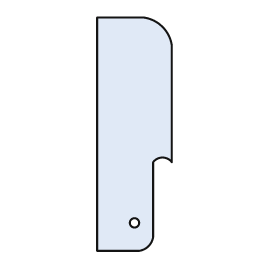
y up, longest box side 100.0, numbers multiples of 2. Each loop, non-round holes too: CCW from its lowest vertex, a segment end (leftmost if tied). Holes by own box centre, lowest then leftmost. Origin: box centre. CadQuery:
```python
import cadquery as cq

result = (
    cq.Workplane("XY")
    .moveTo(-16.0, -50.0)
    .lineTo(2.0, -50.0)
    .threePointArc((6.0, -48.0), (8.0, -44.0))
    .lineTo(8.0, -12.0)
    .threePointArc((12.0, -10.0), (16.0, -12.0))
    .lineTo(16.0, 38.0)
    .threePointArc((12.0, 46.0), (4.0, 50.0))
    .lineTo(-16.0, 50.0)
    .close()
    .moveTo(0.0, -38.0)
    .circle(2.0)
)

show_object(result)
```